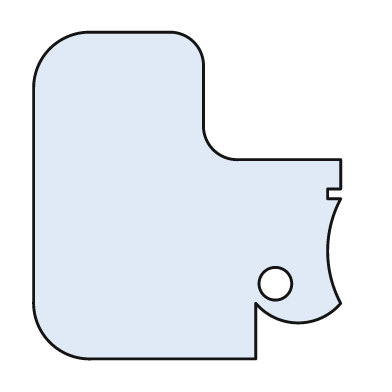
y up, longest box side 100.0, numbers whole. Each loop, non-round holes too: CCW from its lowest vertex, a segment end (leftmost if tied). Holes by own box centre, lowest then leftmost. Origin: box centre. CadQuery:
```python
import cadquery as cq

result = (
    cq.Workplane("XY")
    .moveTo(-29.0, -50.0)
    .lineTo(21.0, -50.0)
    .lineTo(21.0, -33.0)
    .threePointArc((34.0, -39.0), (47.0, -33.0))
    .threePointArc((43.0, -17.0), (47.0, -1.0))
    .lineTo(43.0, -1.0)
    .lineTo(43.0, 2.0)
    .lineTo(47.0, 2.0)
    .lineTo(47.0, 11.0)
    .lineTo(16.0, 11.0)
    .threePointArc((8.0, 14.0), (5.0, 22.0))
    .lineTo(5.0, 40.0)
    .threePointArc((2.0, 47.0), (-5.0, 50.0))
    .lineTo(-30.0, 50.0)
    .threePointArc((-42.0, 45.0), (-47.0, 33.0))
    .lineTo(-47.0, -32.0)
    .threePointArc((-42.0, -45.0), (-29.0, -50.0))
    .close()
    .moveTo(27.0, -27.0)
    .circle(5.0)
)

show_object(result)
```